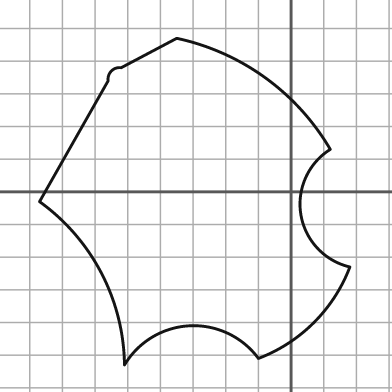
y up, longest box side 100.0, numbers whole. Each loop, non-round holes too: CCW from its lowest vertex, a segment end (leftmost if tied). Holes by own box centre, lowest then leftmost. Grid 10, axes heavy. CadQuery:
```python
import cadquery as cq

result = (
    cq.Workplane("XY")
    .moveTo(-51.0, -53.0)
    .threePointArc((-31.0, -41.0), (-10.0, -51.0))
    .threePointArc((7.0, -40.0), (18.0, -23.0))
    .threePointArc((3.0, -7.0), (12.0, 13.0))
    .threePointArc((-8.0, 35.0), (-35.0, 47.0))
    .lineTo(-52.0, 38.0)
    .threePointArc((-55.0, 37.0), (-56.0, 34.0))
    .lineTo(-77.0, -3.0)
    .threePointArc((-58.0, -25.0), (-51.0, -53.0))
    .close()
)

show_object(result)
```